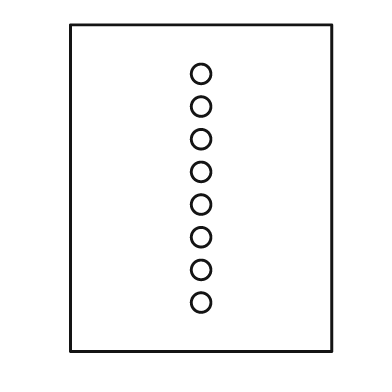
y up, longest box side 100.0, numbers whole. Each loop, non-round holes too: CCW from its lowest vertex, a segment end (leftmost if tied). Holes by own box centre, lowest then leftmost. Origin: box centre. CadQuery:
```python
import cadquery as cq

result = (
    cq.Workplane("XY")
    .moveTo(-40.0, -50.0)
    .lineTo(40.0, -50.0)
    .lineTo(40.0, 50.0)
    .lineTo(-40.0, 50.0)
    .close()
    .moveTo(0.0, -35.0)
    .circle(3.0)
    .moveTo(0.0, -25.0)
    .circle(3.0)
    .moveTo(0.0, -15.0)
    .circle(3.0)
    .moveTo(0.0, -5.0)
    .circle(3.0)
    .moveTo(0.0, 5.0)
    .circle(3.0)
    .moveTo(0.0, 15.0)
    .circle(3.0)
    .moveTo(0.0, 25.0)
    .circle(3.0)
    .moveTo(0.0, 35.0)
    .circle(3.0)
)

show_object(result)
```